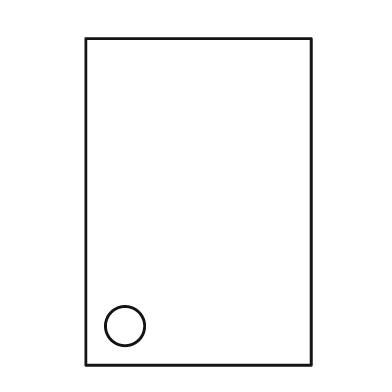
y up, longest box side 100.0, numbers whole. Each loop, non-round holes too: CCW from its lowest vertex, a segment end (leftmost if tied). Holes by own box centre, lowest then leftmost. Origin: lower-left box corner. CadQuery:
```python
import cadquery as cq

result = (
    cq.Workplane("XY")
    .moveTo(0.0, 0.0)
    .lineTo(69.0, 0.0)
    .lineTo(69.0, 100.0)
    .lineTo(0.0, 100.0)
    .close()
    .moveTo(12.0, 12.0)
    .circle(6.0)
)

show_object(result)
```